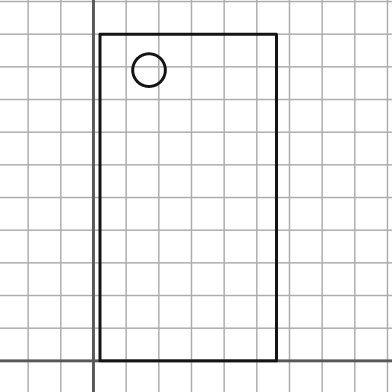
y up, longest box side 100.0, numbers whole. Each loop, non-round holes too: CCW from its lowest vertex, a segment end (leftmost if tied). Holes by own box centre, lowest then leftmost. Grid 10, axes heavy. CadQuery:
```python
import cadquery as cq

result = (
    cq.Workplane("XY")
    .moveTo(2.0, 0.0)
    .lineTo(56.0, 0.0)
    .lineTo(56.0, 100.0)
    .lineTo(2.0, 100.0)
    .close()
    .moveTo(17.0, 89.0)
    .circle(5.0)
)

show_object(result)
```